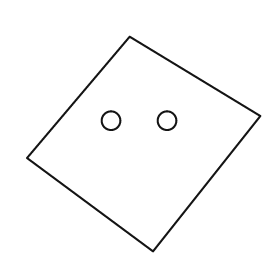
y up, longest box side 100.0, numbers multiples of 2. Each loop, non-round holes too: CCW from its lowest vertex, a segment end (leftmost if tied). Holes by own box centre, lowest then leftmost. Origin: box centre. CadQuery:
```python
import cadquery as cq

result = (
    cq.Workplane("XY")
    .moveTo(4.0, -46.0)
    .lineTo(50.0, 12.0)
    .lineTo(-6.0, 46.0)
    .lineTo(-50.0, -6.0)
    .close()
    .moveTo(-14.0, 10.0)
    .circle(4.0)
    .moveTo(10.0, 10.0)
    .circle(4.0)
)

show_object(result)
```